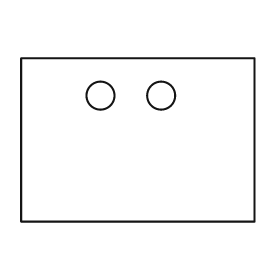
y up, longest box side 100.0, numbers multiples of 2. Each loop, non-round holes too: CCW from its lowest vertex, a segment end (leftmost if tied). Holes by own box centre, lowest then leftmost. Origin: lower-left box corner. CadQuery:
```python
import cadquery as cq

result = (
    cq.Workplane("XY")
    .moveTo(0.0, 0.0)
    .lineTo(100.0, 0.0)
    .lineTo(100.0, 70.0)
    .lineTo(0.0, 70.0)
    .close()
    .moveTo(34.0, 54.0)
    .circle(6.0)
    .moveTo(60.0, 54.0)
    .circle(6.0)
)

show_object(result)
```